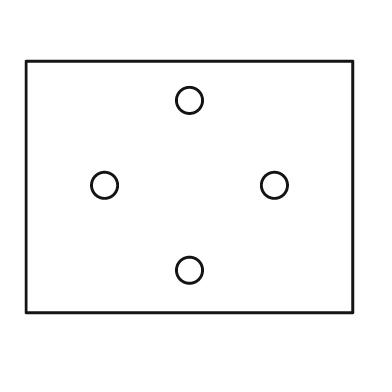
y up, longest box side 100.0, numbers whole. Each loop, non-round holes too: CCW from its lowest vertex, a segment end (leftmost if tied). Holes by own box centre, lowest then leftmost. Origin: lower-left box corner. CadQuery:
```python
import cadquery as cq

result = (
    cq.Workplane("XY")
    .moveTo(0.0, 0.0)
    .lineTo(100.0, 0.0)
    .lineTo(100.0, 77.0)
    .lineTo(0.0, 77.0)
    .close()
    .moveTo(50.0, 13.0)
    .circle(4.0)
    .moveTo(24.0, 39.0)
    .circle(4.0)
    .moveTo(76.0, 39.0)
    .circle(4.0)
    .moveTo(50.0, 65.0)
    .circle(4.0)
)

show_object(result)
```